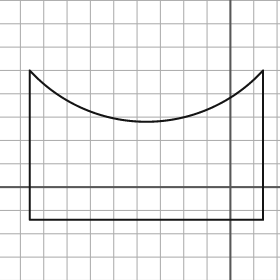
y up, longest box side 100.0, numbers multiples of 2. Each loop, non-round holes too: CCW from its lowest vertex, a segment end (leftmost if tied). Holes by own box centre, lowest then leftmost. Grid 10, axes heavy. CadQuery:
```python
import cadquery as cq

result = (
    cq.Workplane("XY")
    .moveTo(-86.0, -14.0)
    .lineTo(14.0, -14.0)
    .lineTo(14.0, 50.0)
    .threePointArc((-36.0, 28.0), (-86.0, 50.0))
    .close()
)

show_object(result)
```